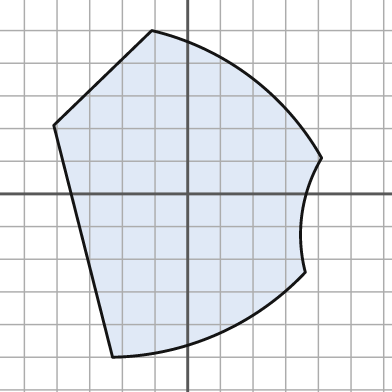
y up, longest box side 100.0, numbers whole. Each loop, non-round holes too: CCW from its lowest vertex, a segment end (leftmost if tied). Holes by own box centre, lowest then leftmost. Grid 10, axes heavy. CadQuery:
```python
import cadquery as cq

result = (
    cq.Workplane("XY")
    .moveTo(-23.0, -50.0)
    .threePointArc((9.0, -43.0), (36.0, -24.0))
    .threePointArc((35.0, -6.0), (41.0, 11.0))
    .threePointArc((19.0, 36.0), (-11.0, 50.0))
    .lineTo(-41.0, 21.0)
    .close()
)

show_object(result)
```